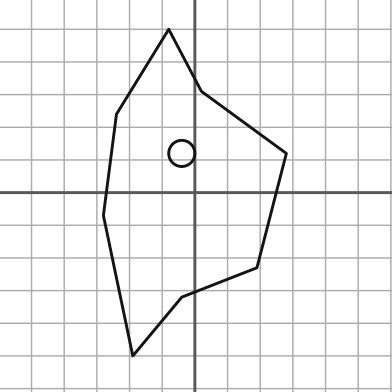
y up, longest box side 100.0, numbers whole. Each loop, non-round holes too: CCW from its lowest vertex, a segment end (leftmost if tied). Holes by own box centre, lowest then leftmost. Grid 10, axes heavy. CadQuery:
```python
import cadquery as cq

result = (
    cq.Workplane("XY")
    .moveTo(-19.0, -50.0)
    .lineTo(-4.0, -32.0)
    .lineTo(19.0, -23.0)
    .lineTo(28.0, 12.0)
    .lineTo(2.0, 31.0)
    .lineTo(-8.0, 50.0)
    .lineTo(-24.0, 24.0)
    .lineTo(-28.0, -7.0)
    .close()
    .moveTo(-4.0, 12.0)
    .circle(4.0)
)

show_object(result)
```